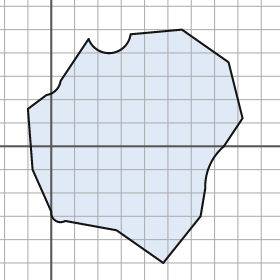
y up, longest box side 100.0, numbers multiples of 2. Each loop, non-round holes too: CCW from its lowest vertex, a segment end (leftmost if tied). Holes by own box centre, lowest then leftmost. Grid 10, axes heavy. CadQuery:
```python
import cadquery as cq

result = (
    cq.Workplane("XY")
    .moveTo(48.0, -50.0)
    .lineTo(64.0, -30.0)
    .lineTo(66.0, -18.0)
    .threePointArc((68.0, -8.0), (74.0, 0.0))
    .lineTo(82.0, 12.0)
    .lineTo(76.0, 36.0)
    .lineTo(56.0, 50.0)
    .lineTo(34.0, 48.0)
    .threePointArc((26.0, 40.0), (16.0, 46.0))
    .lineTo(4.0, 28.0)
    .threePointArc((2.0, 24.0), (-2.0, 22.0))
    .lineTo(-10.0, 16.0)
    .lineTo(-8.0, -10.0)
    .lineTo(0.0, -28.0)
    .threePointArc((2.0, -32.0), (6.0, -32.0))
    .lineTo(28.0, -36.0)
    .close()
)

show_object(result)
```